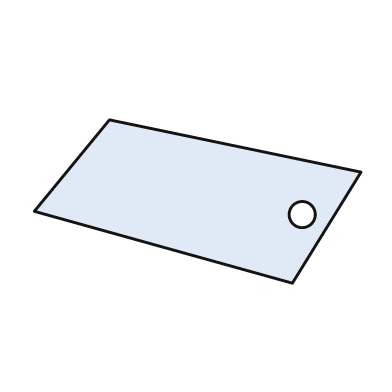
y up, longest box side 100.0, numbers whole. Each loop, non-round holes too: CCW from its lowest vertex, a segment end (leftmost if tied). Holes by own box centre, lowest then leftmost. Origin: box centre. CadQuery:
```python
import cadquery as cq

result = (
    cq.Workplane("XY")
    .moveTo(29.0, -25.0)
    .lineTo(50.0, 9.0)
    .lineTo(-27.0, 25.0)
    .lineTo(-50.0, -3.0)
    .close()
    .moveTo(32.0, -4.0)
    .circle(4.0)
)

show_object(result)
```